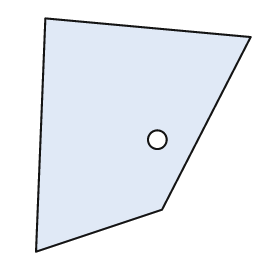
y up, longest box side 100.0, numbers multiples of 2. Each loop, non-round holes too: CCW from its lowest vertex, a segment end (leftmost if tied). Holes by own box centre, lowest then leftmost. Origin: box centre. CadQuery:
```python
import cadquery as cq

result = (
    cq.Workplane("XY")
    .moveTo(-46.0, -50.0)
    .lineTo(8.0, -32.0)
    .lineTo(46.0, 42.0)
    .lineTo(-42.0, 50.0)
    .close()
    .moveTo(6.0, -2.0)
    .circle(4.0)
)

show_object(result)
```